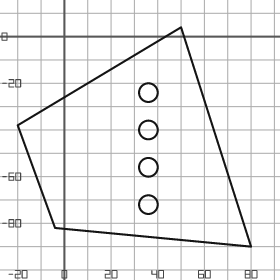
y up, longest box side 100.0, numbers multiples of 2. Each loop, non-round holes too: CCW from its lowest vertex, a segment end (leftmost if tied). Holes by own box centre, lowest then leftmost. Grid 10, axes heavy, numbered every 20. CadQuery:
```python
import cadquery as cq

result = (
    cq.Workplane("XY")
    .moveTo(80.0, -90.0)
    .lineTo(50.0, 4.0)
    .lineTo(-20.0, -38.0)
    .lineTo(-4.0, -82.0)
    .close()
    .moveTo(36.0, -72.0)
    .circle(4.0)
    .moveTo(36.0, -56.0)
    .circle(4.0)
    .moveTo(36.0, -40.0)
    .circle(4.0)
    .moveTo(36.0, -24.0)
    .circle(4.0)
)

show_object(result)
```